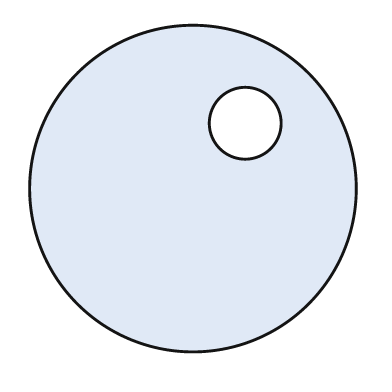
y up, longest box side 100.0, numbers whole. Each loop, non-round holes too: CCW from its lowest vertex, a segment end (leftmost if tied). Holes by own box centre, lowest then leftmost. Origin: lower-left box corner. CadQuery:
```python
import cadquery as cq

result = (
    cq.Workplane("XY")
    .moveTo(50.0, 50.0)
    .circle(50.0)
    .moveTo(66.0, 70.0)
    .circle(11.0)
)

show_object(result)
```